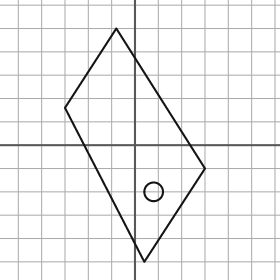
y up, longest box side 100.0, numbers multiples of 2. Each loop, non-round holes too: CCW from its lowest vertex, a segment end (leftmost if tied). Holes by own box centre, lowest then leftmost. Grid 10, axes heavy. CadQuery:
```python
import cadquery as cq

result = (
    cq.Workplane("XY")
    .moveTo(4.0, -50.0)
    .lineTo(30.0, -10.0)
    .lineTo(-8.0, 50.0)
    .lineTo(-30.0, 16.0)
    .close()
    .moveTo(8.0, -20.0)
    .circle(4.0)
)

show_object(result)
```